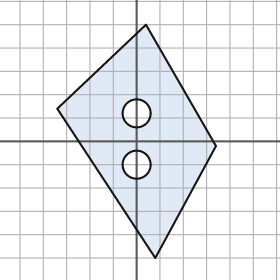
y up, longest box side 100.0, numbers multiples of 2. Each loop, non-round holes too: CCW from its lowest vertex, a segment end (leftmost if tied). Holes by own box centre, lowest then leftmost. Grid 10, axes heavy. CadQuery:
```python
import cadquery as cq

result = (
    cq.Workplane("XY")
    .moveTo(8.0, -50.0)
    .lineTo(34.0, -2.0)
    .lineTo(4.0, 50.0)
    .lineTo(-34.0, 14.0)
    .close()
    .moveTo(0.0, -10.0)
    .circle(6.0)
    .moveTo(0.0, 12.0)
    .circle(6.0)
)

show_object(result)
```